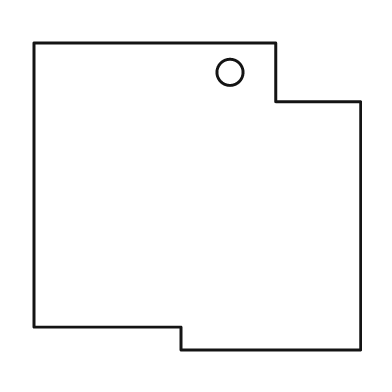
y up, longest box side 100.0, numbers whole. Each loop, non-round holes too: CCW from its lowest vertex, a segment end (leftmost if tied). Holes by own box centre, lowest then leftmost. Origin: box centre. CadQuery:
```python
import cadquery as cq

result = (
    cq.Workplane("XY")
    .moveTo(-5.0, -47.0)
    .lineTo(50.0, -47.0)
    .lineTo(50.0, 29.0)
    .lineTo(24.0, 29.0)
    .lineTo(24.0, 47.0)
    .lineTo(-50.0, 47.0)
    .lineTo(-50.0, -40.0)
    .lineTo(-5.0, -40.0)
    .close()
    .moveTo(10.0, 38.0)
    .circle(4.0)
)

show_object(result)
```